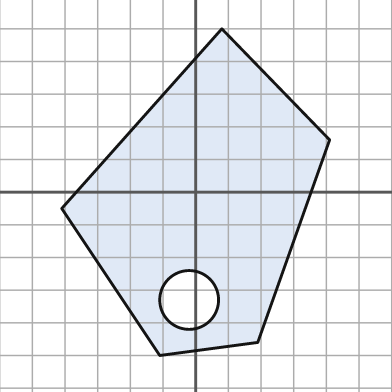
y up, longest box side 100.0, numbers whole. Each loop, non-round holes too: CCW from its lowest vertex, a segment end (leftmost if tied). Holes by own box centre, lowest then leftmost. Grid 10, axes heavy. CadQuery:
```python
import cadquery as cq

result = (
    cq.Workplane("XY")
    .moveTo(-11.0, -50.0)
    .lineTo(19.0, -46.0)
    .lineTo(41.0, 16.0)
    .lineTo(8.0, 50.0)
    .lineTo(-41.0, -5.0)
    .close()
    .moveTo(-2.0, -33.0)
    .circle(9.0)
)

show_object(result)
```